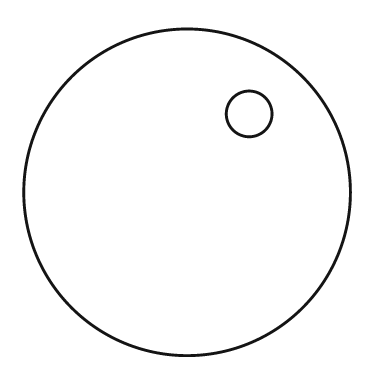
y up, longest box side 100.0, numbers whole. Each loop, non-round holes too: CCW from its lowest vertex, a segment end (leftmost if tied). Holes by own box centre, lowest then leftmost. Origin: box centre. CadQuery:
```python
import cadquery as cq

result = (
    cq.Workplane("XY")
    .moveTo(0.0, 0.0)
    .circle(50.0)
    .moveTo(19.0, 24.0)
    .circle(7.0)
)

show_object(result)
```